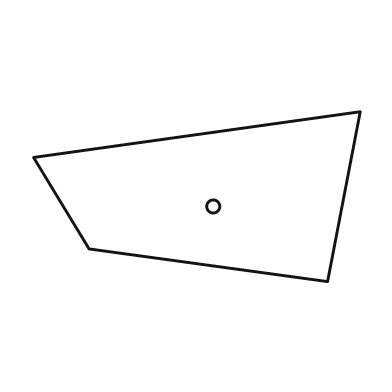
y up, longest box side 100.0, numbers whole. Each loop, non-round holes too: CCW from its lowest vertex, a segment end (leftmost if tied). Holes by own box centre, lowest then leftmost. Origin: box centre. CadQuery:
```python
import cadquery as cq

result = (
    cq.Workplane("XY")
    .moveTo(40.0, -26.0)
    .lineTo(50.0, 26.0)
    .lineTo(-50.0, 12.0)
    .lineTo(-33.0, -16.0)
    .close()
    .moveTo(5.0, -3.0)
    .circle(2.0)
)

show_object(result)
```